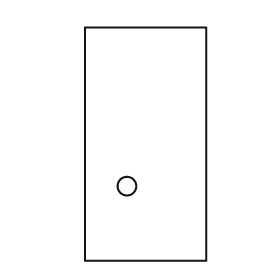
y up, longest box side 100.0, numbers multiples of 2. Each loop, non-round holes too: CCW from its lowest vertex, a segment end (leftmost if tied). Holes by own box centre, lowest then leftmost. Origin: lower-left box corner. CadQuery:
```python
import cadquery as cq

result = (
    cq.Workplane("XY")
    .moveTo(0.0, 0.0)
    .lineTo(52.0, 0.0)
    .lineTo(52.0, 100.0)
    .lineTo(0.0, 100.0)
    .close()
    .moveTo(18.0, 32.0)
    .circle(4.0)
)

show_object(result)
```